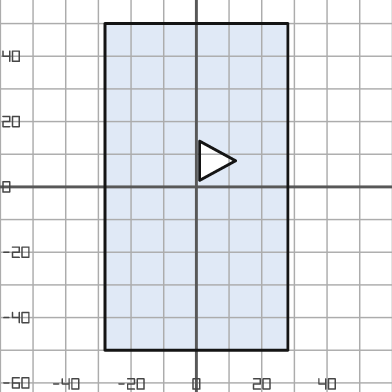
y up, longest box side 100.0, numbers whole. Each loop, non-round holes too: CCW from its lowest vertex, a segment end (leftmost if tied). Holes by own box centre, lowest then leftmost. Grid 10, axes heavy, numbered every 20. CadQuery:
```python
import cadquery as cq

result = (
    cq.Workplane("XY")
    .moveTo(-28.0, -50.0)
    .lineTo(28.0, -50.0)
    .lineTo(28.0, 50.0)
    .lineTo(-28.0, 50.0)
    .close()
    .moveTo(1.0, 2.0)
    .lineTo(12.0, 8.0)
    .lineTo(1.0, 14.0)
    .close()
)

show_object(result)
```